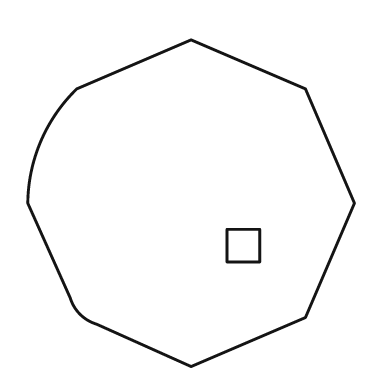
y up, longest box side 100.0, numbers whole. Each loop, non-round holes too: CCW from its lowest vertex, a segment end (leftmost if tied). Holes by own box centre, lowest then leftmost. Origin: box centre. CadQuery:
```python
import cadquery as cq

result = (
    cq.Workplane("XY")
    .moveTo(0.0, -50.0)
    .lineTo(35.0, -35.0)
    .lineTo(50.0, 0.0)
    .lineTo(35.0, 35.0)
    .lineTo(0.0, 50.0)
    .lineTo(-35.0, 35.0)
    .threePointArc((-46.0, 19.0), (-50.0, 0.0))
    .lineTo(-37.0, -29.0)
    .threePointArc((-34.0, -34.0), (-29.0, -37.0))
    .close()
    .moveTo(11.0, -18.0)
    .lineTo(21.0, -18.0)
    .lineTo(21.0, -8.0)
    .lineTo(11.0, -8.0)
    .close()
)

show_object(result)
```